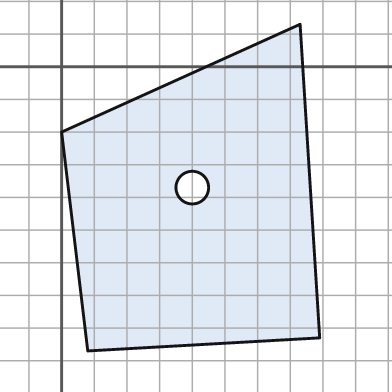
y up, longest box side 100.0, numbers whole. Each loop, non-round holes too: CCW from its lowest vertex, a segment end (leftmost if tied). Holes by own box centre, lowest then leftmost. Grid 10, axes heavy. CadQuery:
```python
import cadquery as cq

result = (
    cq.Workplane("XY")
    .moveTo(8.0, -87.0)
    .lineTo(79.0, -83.0)
    .lineTo(73.0, 13.0)
    .lineTo(0.0, -20.0)
    .close()
    .moveTo(40.0, -37.0)
    .circle(5.0)
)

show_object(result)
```